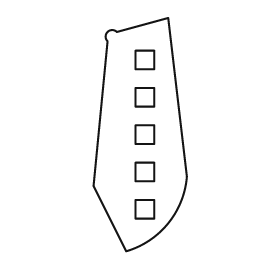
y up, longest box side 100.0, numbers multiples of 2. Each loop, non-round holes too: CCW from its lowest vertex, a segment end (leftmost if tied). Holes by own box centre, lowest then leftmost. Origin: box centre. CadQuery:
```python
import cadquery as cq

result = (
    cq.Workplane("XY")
    .moveTo(-6.0, -50.0)
    .threePointArc((12.0, -38.0), (20.0, -18.0))
    .lineTo(12.0, 50.0)
    .lineTo(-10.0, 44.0)
    .threePointArc((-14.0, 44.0), (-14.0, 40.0))
    .lineTo(-20.0, -22.0)
    .close()
    .moveTo(-2.0, -36.0)
    .lineTo(6.0, -36.0)
    .lineTo(6.0, -28.0)
    .lineTo(-2.0, -28.0)
    .close()
    .moveTo(-2.0, -20.0)
    .lineTo(6.0, -20.0)
    .lineTo(6.0, -12.0)
    .lineTo(-2.0, -12.0)
    .close()
    .moveTo(-2.0, -4.0)
    .lineTo(6.0, -4.0)
    .lineTo(6.0, 4.0)
    .lineTo(-2.0, 4.0)
    .close()
    .moveTo(-2.0, 12.0)
    .lineTo(6.0, 12.0)
    .lineTo(6.0, 20.0)
    .lineTo(-2.0, 20.0)
    .close()
    .moveTo(-2.0, 28.0)
    .lineTo(6.0, 28.0)
    .lineTo(6.0, 36.0)
    .lineTo(-2.0, 36.0)
    .close()
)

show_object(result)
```